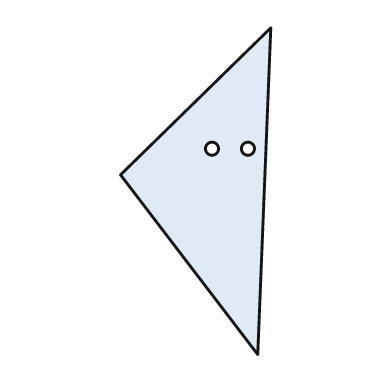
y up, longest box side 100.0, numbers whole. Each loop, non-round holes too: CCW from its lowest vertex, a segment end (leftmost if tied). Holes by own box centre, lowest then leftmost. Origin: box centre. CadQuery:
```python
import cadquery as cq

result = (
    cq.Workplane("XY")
    .moveTo(19.0, -50.0)
    .lineTo(23.0, 50.0)
    .lineTo(-23.0, 5.0)
    .close()
    .moveTo(5.0, 13.0)
    .circle(2.0)
    .moveTo(16.0, 13.0)
    .circle(2.0)
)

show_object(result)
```